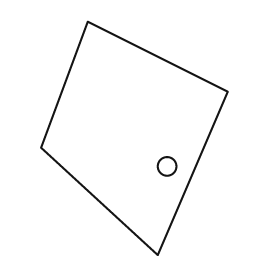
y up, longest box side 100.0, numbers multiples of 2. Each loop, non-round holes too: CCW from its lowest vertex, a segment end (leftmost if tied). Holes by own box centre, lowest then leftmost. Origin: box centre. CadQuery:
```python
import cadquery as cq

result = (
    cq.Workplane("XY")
    .moveTo(10.0, -50.0)
    .lineTo(40.0, 20.0)
    .lineTo(-20.0, 50.0)
    .lineTo(-40.0, -4.0)
    .close()
    .moveTo(14.0, -12.0)
    .circle(4.0)
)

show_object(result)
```